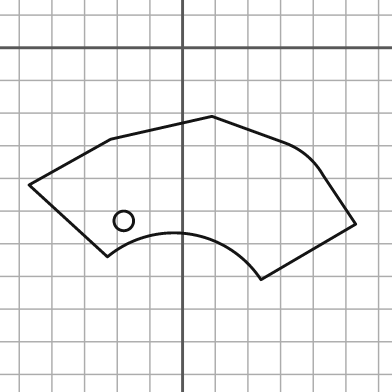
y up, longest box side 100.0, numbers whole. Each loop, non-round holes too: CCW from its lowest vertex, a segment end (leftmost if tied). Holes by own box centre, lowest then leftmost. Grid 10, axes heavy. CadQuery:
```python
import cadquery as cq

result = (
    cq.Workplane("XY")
    .moveTo(24.0, -71.0)
    .lineTo(53.0, -54.0)
    .lineTo(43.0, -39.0)
    .threePointArc((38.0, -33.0), (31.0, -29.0))
    .lineTo(9.0, -21.0)
    .lineTo(-22.0, -28.0)
    .lineTo(-47.0, -42.0)
    .lineTo(-23.0, -64.0)
    .threePointArc((2.0, -57.0), (24.0, -71.0))
    .close()
    .moveTo(-18.0, -53.0)
    .circle(3.0)
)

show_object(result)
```